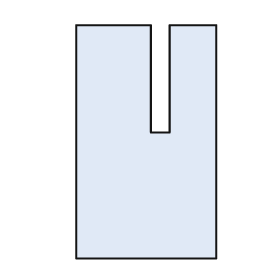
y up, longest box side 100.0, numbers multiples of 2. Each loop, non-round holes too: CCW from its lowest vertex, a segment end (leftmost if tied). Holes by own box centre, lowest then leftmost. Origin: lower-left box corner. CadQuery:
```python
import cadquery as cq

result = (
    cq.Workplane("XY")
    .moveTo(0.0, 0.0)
    .lineTo(60.0, 0.0)
    .lineTo(60.0, 100.0)
    .lineTo(40.0, 100.0)
    .lineTo(40.0, 54.0)
    .lineTo(32.0, 54.0)
    .lineTo(32.0, 100.0)
    .lineTo(0.0, 100.0)
    .close()
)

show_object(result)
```